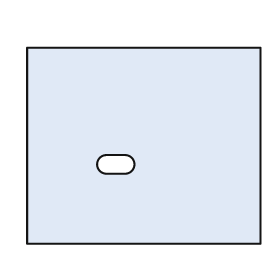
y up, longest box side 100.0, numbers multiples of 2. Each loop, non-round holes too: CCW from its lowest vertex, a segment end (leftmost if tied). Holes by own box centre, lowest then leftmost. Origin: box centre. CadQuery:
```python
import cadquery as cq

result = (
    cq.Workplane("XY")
    .moveTo(-50.0, -42.0)
    .lineTo(50.0, -42.0)
    .lineTo(50.0, 42.0)
    .lineTo(-50.0, 42.0)
    .close()
    .moveTo(-16.0, -12.0)
    .lineTo(-8.0, -12.0)
    .threePointArc((-4.0, -8.0), (-8.0, -4.0))
    .lineTo(-16.0, -4.0)
    .threePointArc((-20.0, -8.0), (-16.0, -12.0))
    .close()
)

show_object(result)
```